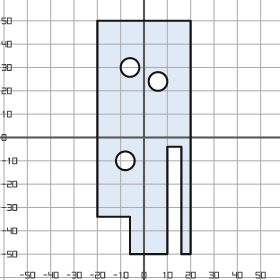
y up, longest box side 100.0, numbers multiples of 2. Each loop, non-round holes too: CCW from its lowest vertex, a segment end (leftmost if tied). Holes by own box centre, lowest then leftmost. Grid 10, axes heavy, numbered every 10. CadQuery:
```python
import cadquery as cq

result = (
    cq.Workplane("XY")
    .moveTo(-6.0, -50.0)
    .lineTo(10.0, -50.0)
    .lineTo(10.0, -4.0)
    .lineTo(16.0, -4.0)
    .lineTo(16.0, -50.0)
    .lineTo(20.0, -50.0)
    .lineTo(20.0, 50.0)
    .lineTo(-20.0, 50.0)
    .lineTo(-20.0, -34.0)
    .lineTo(-6.0, -34.0)
    .close()
    .moveTo(-8.0, -10.0)
    .circle(4.0)
    .moveTo(6.0, 24.0)
    .circle(4.0)
    .moveTo(-6.0, 30.0)
    .circle(4.0)
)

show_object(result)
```